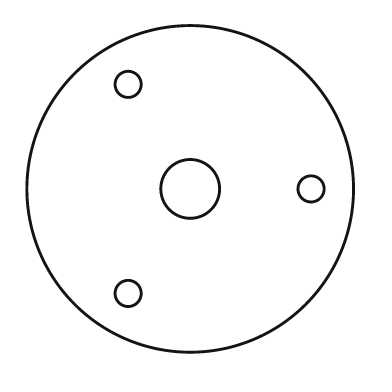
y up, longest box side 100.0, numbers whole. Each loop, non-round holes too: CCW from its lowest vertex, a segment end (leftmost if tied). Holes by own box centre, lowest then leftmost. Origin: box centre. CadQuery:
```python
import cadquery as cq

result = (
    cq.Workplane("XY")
    .moveTo(0.0, 0.0)
    .circle(50.0)
    .moveTo(-19.0, -32.0)
    .circle(4.0)
    .moveTo(0.0, 0.0)
    .circle(9.0)
    .moveTo(37.0, 0.0)
    .circle(4.0)
    .moveTo(-19.0, 32.0)
    .circle(4.0)
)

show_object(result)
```